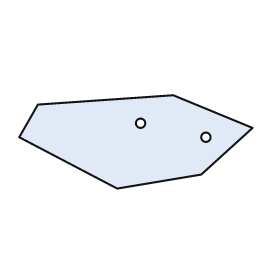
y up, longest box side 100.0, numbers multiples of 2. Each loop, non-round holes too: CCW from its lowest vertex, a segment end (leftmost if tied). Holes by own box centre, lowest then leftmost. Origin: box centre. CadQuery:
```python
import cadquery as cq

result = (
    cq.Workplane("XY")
    .moveTo(-8.0, -20.0)
    .lineTo(28.0, -14.0)
    .lineTo(50.0, 6.0)
    .lineTo(16.0, 20.0)
    .lineTo(-42.0, 16.0)
    .lineTo(-50.0, 2.0)
    .close()
    .moveTo(30.0, 2.0)
    .circle(2.0)
    .moveTo(2.0, 8.0)
    .circle(2.0)
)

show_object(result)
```